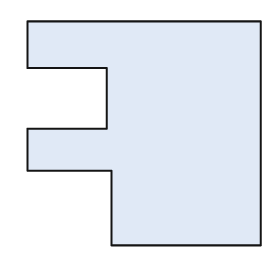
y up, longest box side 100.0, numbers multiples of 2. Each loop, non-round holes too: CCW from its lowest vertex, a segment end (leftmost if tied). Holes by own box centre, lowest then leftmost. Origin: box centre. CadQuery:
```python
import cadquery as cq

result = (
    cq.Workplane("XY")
    .moveTo(-14.0, -48.0)
    .lineTo(50.0, -48.0)
    .lineTo(50.0, 48.0)
    .lineTo(-50.0, 48.0)
    .lineTo(-50.0, 28.0)
    .lineTo(-16.0, 28.0)
    .lineTo(-16.0, 2.0)
    .lineTo(-50.0, 2.0)
    .lineTo(-50.0, -16.0)
    .lineTo(-14.0, -16.0)
    .close()
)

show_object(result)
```